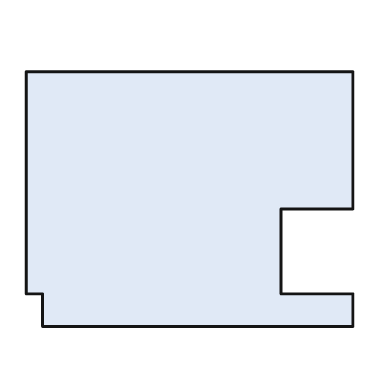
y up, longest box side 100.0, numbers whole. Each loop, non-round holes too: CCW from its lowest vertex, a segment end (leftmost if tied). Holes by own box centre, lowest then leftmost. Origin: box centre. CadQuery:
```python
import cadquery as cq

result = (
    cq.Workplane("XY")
    .moveTo(-45.0, -39.0)
    .lineTo(50.0, -39.0)
    .lineTo(50.0, -29.0)
    .lineTo(28.0, -29.0)
    .lineTo(28.0, -3.0)
    .lineTo(50.0, -3.0)
    .lineTo(50.0, 39.0)
    .lineTo(-50.0, 39.0)
    .lineTo(-50.0, -29.0)
    .lineTo(-45.0, -29.0)
    .close()
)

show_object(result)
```